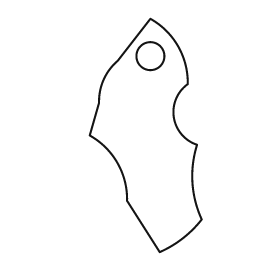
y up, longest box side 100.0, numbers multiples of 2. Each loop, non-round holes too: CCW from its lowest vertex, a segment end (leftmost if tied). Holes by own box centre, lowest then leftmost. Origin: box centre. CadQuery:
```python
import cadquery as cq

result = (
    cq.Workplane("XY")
    .moveTo(6.0, -50.0)
    .threePointArc((16.0, -44.0), (24.0, -36.0))
    .threePointArc((20.0, -20.0), (22.0, -4.0))
    .threePointArc((12.0, 8.0), (18.0, 22.0))
    .threePointArc((14.0, 38.0), (2.0, 50.0))
    .lineTo(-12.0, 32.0)
    .threePointArc((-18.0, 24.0), (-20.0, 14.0))
    .lineTo(-24.0, 0.0)
    .threePointArc((-12.0, -12.0), (-8.0, -28.0))
    .close()
    .moveTo(2.0, 34.0)
    .circle(6.0)
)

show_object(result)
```